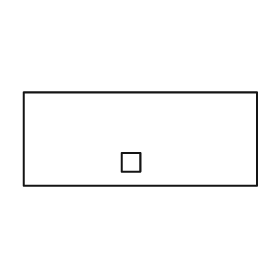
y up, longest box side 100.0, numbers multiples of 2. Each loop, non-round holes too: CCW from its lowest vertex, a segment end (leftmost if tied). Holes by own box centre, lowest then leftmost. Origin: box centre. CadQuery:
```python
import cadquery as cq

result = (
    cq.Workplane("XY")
    .moveTo(-50.0, -20.0)
    .lineTo(50.0, -20.0)
    .lineTo(50.0, 20.0)
    .lineTo(-50.0, 20.0)
    .close()
    .moveTo(-8.0, -14.0)
    .lineTo(0.0, -14.0)
    .lineTo(0.0, -6.0)
    .lineTo(-8.0, -6.0)
    .close()
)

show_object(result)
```